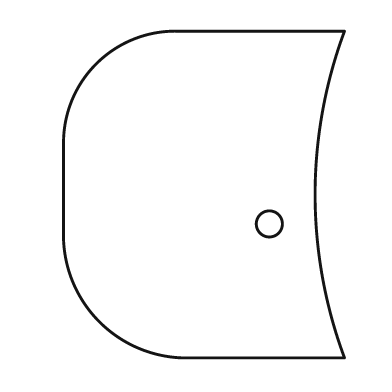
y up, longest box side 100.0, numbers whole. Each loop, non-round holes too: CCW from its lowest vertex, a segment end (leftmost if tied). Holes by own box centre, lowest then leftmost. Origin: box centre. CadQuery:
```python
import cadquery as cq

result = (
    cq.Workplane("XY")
    .moveTo(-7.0, -50.0)
    .lineTo(43.0, -50.0)
    .threePointArc((34.0, 0.0), (43.0, 50.0))
    .lineTo(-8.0, 50.0)
    .threePointArc((-33.0, 40.0), (-43.0, 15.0))
    .lineTo(-43.0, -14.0)
    .threePointArc((-32.0, -39.0), (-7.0, -50.0))
    .close()
    .moveTo(20.0, -9.0)
    .circle(4.0)
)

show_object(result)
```